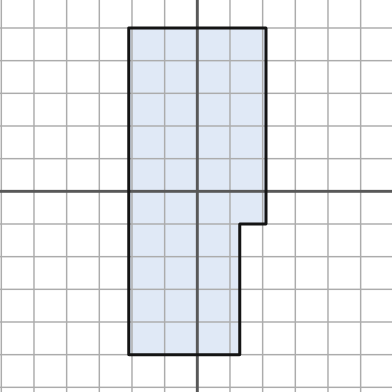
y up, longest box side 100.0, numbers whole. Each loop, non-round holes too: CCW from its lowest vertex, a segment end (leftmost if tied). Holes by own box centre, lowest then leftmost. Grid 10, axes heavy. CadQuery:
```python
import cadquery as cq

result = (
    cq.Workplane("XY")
    .moveTo(-21.0, -50.0)
    .lineTo(13.0, -50.0)
    .lineTo(13.0, -10.0)
    .lineTo(21.0, -10.0)
    .lineTo(21.0, 50.0)
    .lineTo(-21.0, 50.0)
    .close()
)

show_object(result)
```